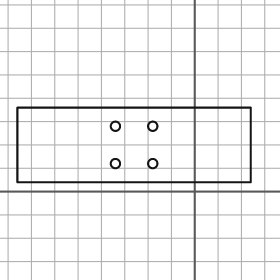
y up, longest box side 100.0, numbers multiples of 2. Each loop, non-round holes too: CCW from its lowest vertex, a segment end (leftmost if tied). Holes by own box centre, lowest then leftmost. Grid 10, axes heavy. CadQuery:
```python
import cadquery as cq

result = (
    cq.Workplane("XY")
    .moveTo(-76.0, 4.0)
    .lineTo(24.0, 4.0)
    .lineTo(24.0, 36.0)
    .lineTo(-76.0, 36.0)
    .close()
    .moveTo(-34.0, 12.0)
    .circle(2.0)
    .moveTo(-18.0, 12.0)
    .circle(2.0)
    .moveTo(-34.0, 28.0)
    .circle(2.0)
    .moveTo(-18.0, 28.0)
    .circle(2.0)
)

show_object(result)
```